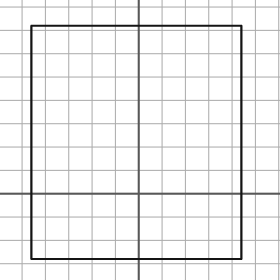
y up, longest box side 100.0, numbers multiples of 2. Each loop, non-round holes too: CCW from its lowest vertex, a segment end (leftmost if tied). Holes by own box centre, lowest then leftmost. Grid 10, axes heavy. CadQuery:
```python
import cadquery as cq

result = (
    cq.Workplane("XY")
    .moveTo(-46.0, -28.0)
    .lineTo(44.0, -28.0)
    .lineTo(44.0, 72.0)
    .lineTo(-46.0, 72.0)
    .close()
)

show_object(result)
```